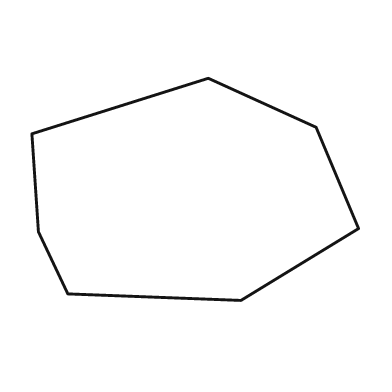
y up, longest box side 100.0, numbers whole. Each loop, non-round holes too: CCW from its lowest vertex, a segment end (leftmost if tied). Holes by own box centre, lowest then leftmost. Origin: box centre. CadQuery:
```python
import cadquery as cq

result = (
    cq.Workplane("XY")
    .moveTo(14.0, -34.0)
    .lineTo(50.0, -12.0)
    .lineTo(37.0, 19.0)
    .lineTo(4.0, 34.0)
    .lineTo(-50.0, 17.0)
    .lineTo(-48.0, -13.0)
    .lineTo(-39.0, -32.0)
    .close()
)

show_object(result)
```